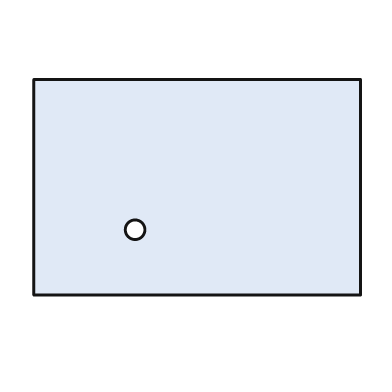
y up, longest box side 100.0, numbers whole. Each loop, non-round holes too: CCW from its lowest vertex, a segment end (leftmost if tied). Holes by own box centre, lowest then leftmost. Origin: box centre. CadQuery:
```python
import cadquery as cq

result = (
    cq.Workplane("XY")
    .moveTo(-50.0, -33.0)
    .lineTo(50.0, -33.0)
    .lineTo(50.0, 33.0)
    .lineTo(-50.0, 33.0)
    .close()
    .moveTo(-19.0, -13.0)
    .circle(3.0)
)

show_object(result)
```